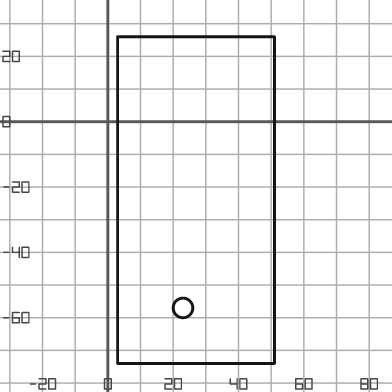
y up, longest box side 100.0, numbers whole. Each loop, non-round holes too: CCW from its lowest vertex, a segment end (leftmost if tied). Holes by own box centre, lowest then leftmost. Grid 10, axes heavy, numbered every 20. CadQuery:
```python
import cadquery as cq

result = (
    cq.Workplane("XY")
    .moveTo(3.0, -74.0)
    .lineTo(51.0, -74.0)
    .lineTo(51.0, 26.0)
    .lineTo(3.0, 26.0)
    .close()
    .moveTo(23.0, -57.0)
    .circle(3.0)
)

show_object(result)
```